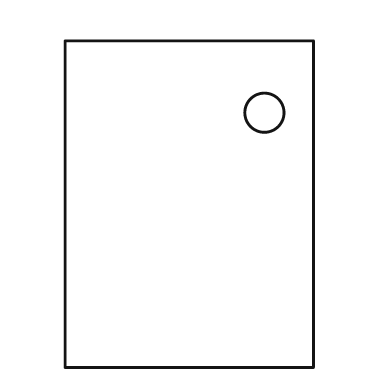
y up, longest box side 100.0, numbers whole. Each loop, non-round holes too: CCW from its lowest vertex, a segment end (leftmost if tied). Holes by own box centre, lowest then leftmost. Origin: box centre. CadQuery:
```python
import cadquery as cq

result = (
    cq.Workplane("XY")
    .moveTo(-38.0, -50.0)
    .lineTo(38.0, -50.0)
    .lineTo(38.0, 50.0)
    .lineTo(-38.0, 50.0)
    .close()
    .moveTo(23.0, 28.0)
    .circle(6.0)
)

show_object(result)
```